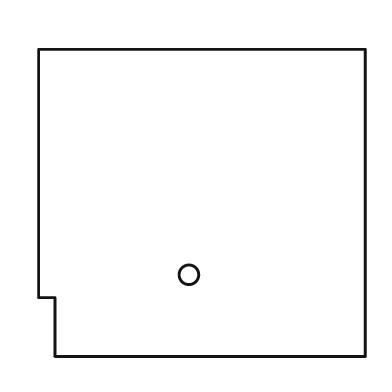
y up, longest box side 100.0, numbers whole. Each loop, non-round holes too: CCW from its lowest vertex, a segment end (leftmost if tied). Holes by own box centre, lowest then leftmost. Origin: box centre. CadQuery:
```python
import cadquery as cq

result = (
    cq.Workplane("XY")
    .moveTo(-45.0, -47.0)
    .lineTo(50.0, -47.0)
    .lineTo(50.0, 47.0)
    .lineTo(-50.0, 47.0)
    .lineTo(-50.0, -29.0)
    .lineTo(-45.0, -29.0)
    .close()
    .moveTo(-4.0, -22.0)
    .circle(3.0)
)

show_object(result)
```